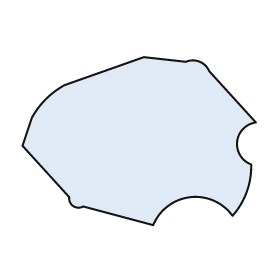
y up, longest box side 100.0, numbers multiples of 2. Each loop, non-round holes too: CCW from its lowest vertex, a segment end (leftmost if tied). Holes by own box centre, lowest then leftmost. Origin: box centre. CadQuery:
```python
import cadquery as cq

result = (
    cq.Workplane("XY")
    .moveTo(6.0, -36.0)
    .threePointArc((22.0, -24.0), (40.0, -32.0))
    .threePointArc((46.0, -22.0), (48.0, -10.0))
    .threePointArc((42.0, 0.0), (50.0, 8.0))
    .lineTo(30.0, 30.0)
    .threePointArc((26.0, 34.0), (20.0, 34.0))
    .lineTo(2.0, 36.0)
    .lineTo(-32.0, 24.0)
    .threePointArc((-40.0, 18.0), (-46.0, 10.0))
    .lineTo(-50.0, -2.0)
    .lineTo(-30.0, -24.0)
    .threePointArc((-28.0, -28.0), (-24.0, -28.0))
    .close()
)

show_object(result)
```